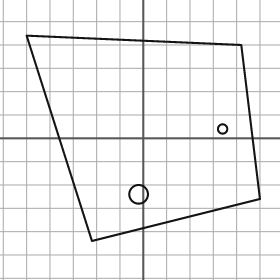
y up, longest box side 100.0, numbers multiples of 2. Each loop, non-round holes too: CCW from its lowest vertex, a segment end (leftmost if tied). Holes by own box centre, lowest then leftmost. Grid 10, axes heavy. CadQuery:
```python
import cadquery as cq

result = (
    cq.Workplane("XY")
    .moveTo(-22.0, -44.0)
    .lineTo(50.0, -26.0)
    .lineTo(42.0, 40.0)
    .lineTo(-50.0, 44.0)
    .close()
    .moveTo(-2.0, -24.0)
    .circle(4.0)
    .moveTo(34.0, 4.0)
    .circle(2.0)
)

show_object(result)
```